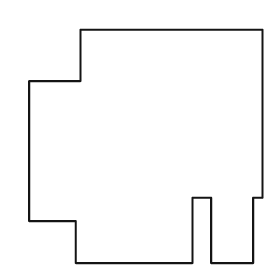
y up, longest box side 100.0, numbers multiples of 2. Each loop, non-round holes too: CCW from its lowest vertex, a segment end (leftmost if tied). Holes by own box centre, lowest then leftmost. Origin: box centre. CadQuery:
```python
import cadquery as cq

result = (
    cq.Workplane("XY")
    .moveTo(-30.0, -50.0)
    .lineTo(20.0, -50.0)
    .lineTo(20.0, -22.0)
    .lineTo(28.0, -22.0)
    .lineTo(28.0, -50.0)
    .lineTo(46.0, -50.0)
    .lineTo(46.0, -22.0)
    .lineTo(50.0, -22.0)
    .lineTo(50.0, 50.0)
    .lineTo(-28.0, 50.0)
    .lineTo(-28.0, 28.0)
    .lineTo(-50.0, 28.0)
    .lineTo(-50.0, -32.0)
    .lineTo(-30.0, -32.0)
    .close()
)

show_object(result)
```